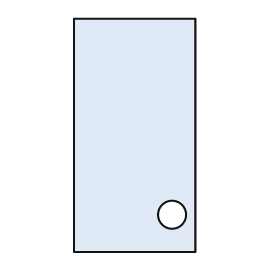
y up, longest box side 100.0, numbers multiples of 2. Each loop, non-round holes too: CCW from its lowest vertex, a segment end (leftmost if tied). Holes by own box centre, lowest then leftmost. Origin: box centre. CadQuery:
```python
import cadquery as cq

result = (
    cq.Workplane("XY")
    .moveTo(-26.0, -50.0)
    .lineTo(26.0, -50.0)
    .lineTo(26.0, 50.0)
    .lineTo(-26.0, 50.0)
    .close()
    .moveTo(16.0, -34.0)
    .circle(6.0)
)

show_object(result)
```